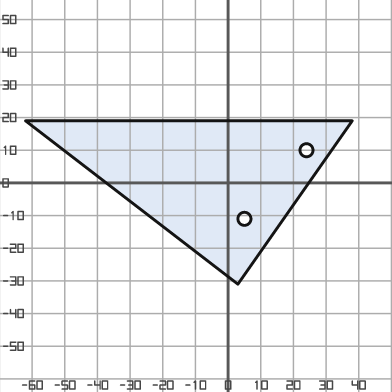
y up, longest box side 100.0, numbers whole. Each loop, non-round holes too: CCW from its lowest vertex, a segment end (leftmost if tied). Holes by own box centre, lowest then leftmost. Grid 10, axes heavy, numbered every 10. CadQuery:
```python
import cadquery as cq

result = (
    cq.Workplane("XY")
    .moveTo(3.0, -31.0)
    .lineTo(38.0, 19.0)
    .lineTo(-62.0, 19.0)
    .close()
    .moveTo(5.0, -11.0)
    .circle(2.0)
    .moveTo(24.0, 10.0)
    .circle(2.0)
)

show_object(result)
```